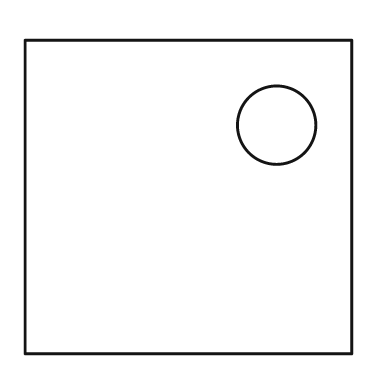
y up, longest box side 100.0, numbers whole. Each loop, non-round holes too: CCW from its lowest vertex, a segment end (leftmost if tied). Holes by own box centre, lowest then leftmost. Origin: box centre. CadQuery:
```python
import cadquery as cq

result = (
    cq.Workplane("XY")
    .moveTo(-50.0, -48.0)
    .lineTo(50.0, -48.0)
    .lineTo(50.0, 48.0)
    .lineTo(-50.0, 48.0)
    .close()
    .moveTo(27.0, 22.0)
    .circle(12.0)
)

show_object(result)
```